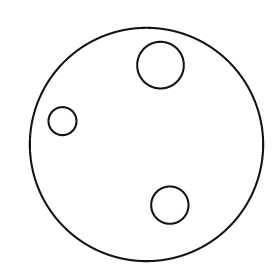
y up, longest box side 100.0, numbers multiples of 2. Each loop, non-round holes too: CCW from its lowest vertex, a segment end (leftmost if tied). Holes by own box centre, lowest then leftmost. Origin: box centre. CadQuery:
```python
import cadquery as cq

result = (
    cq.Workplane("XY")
    .moveTo(0.0, 0.0)
    .circle(50.0)
    .moveTo(10.0, -26.0)
    .circle(8.0)
    .moveTo(-36.0, 10.0)
    .circle(6.0)
    .moveTo(6.0, 34.0)
    .circle(10.0)
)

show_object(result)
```